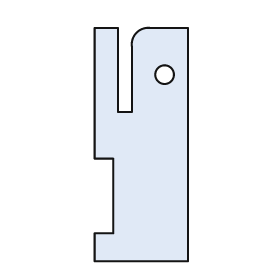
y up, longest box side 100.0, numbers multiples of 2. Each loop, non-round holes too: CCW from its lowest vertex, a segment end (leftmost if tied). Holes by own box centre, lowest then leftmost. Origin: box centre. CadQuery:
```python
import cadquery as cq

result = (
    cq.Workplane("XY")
    .moveTo(-20.0, -50.0)
    .lineTo(20.0, -50.0)
    .lineTo(20.0, 50.0)
    .lineTo(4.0, 50.0)
    .threePointArc((-2.0, 48.0), (-4.0, 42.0))
    .lineTo(-4.0, 14.0)
    .lineTo(-10.0, 14.0)
    .lineTo(-10.0, 50.0)
    .lineTo(-20.0, 50.0)
    .lineTo(-20.0, -6.0)
    .lineTo(-12.0, -6.0)
    .lineTo(-12.0, -38.0)
    .lineTo(-20.0, -38.0)
    .close()
    .moveTo(10.0, 30.0)
    .circle(4.0)
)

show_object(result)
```